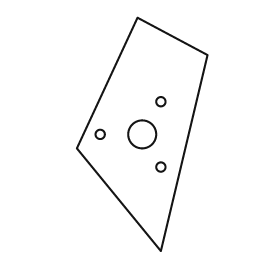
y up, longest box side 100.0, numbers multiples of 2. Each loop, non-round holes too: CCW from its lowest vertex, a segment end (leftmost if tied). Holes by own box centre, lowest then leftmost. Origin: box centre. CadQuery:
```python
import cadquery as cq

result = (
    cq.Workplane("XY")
    .moveTo(8.0, -50.0)
    .lineTo(28.0, 34.0)
    .lineTo(-2.0, 50.0)
    .lineTo(-28.0, -6.0)
    .close()
    .moveTo(8.0, -14.0)
    .circle(2.0)
    .moveTo(-18.0, 0.0)
    .circle(2.0)
    .moveTo(0.0, 0.0)
    .circle(6.0)
    .moveTo(8.0, 14.0)
    .circle(2.0)
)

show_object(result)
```